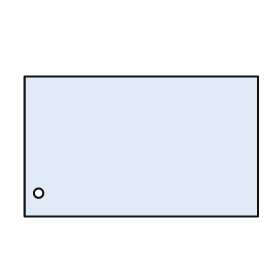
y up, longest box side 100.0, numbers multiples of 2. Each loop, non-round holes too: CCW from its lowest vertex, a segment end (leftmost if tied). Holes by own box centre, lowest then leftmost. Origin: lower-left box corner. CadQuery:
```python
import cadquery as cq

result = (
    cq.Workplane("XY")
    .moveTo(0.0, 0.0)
    .lineTo(100.0, 0.0)
    .lineTo(100.0, 60.0)
    .lineTo(0.0, 60.0)
    .close()
    .moveTo(6.0, 10.0)
    .circle(2.0)
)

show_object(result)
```